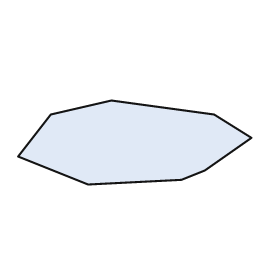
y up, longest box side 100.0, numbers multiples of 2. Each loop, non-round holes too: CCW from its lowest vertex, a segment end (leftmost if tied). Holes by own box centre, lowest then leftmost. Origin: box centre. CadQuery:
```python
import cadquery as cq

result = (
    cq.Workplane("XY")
    .moveTo(-20.0, -18.0)
    .lineTo(20.0, -16.0)
    .lineTo(30.0, -12.0)
    .lineTo(50.0, 2.0)
    .lineTo(34.0, 12.0)
    .lineTo(-10.0, 18.0)
    .lineTo(-36.0, 12.0)
    .lineTo(-50.0, -6.0)
    .close()
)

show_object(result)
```